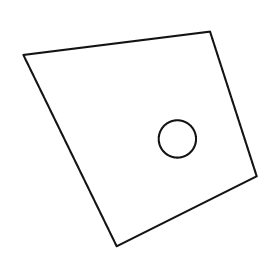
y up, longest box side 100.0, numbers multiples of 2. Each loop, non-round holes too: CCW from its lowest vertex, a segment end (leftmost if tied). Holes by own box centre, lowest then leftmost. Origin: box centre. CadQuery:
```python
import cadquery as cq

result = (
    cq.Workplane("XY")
    .moveTo(-10.0, -46.0)
    .lineTo(50.0, -16.0)
    .lineTo(30.0, 46.0)
    .lineTo(-50.0, 36.0)
    .close()
    .moveTo(16.0, 0.0)
    .circle(8.0)
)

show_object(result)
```